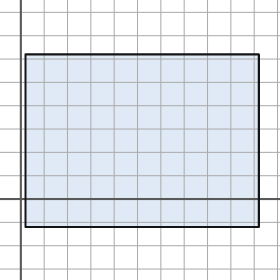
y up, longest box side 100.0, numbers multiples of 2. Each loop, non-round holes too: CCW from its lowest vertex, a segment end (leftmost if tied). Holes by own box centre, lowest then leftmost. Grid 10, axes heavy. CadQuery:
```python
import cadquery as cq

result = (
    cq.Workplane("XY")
    .moveTo(2.0, -12.0)
    .lineTo(102.0, -12.0)
    .lineTo(102.0, 62.0)
    .lineTo(2.0, 62.0)
    .close()
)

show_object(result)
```